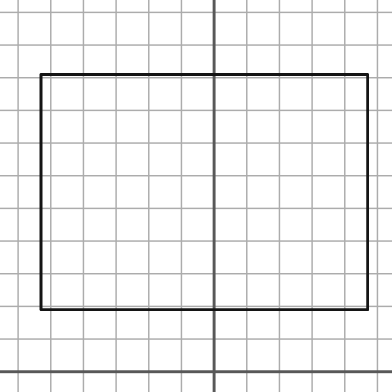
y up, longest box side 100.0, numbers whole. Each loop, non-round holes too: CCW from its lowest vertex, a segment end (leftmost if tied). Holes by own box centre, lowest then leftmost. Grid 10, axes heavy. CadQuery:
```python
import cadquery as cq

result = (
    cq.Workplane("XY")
    .moveTo(-53.0, 19.0)
    .lineTo(47.0, 19.0)
    .lineTo(47.0, 91.0)
    .lineTo(-53.0, 91.0)
    .close()
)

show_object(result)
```